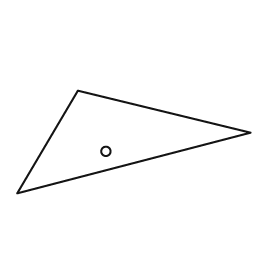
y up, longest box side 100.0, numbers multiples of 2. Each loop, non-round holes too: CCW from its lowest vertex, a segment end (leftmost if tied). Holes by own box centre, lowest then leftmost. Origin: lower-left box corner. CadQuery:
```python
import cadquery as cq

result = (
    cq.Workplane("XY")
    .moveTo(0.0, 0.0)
    .lineTo(100.0, 26.0)
    .lineTo(26.0, 44.0)
    .close()
    .moveTo(38.0, 18.0)
    .circle(2.0)
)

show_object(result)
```